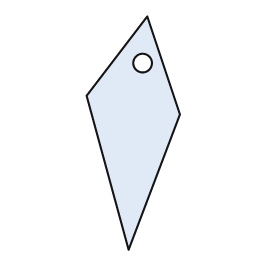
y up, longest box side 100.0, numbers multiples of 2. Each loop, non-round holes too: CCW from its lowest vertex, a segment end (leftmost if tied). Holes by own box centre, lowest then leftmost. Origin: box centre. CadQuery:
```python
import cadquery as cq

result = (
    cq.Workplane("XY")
    .moveTo(-2.0, -50.0)
    .lineTo(20.0, 8.0)
    .lineTo(6.0, 50.0)
    .lineTo(-20.0, 16.0)
    .close()
    .moveTo(4.0, 30.0)
    .circle(4.0)
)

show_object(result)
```